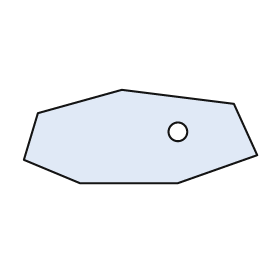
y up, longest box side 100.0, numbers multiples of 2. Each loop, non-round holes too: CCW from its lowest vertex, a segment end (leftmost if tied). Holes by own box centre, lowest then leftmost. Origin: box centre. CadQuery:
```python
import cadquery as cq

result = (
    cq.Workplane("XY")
    .moveTo(-26.0, -20.0)
    .lineTo(16.0, -20.0)
    .lineTo(50.0, -8.0)
    .lineTo(40.0, 14.0)
    .lineTo(-8.0, 20.0)
    .lineTo(-44.0, 10.0)
    .lineTo(-50.0, -10.0)
    .close()
    .moveTo(16.0, 2.0)
    .circle(4.0)
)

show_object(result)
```